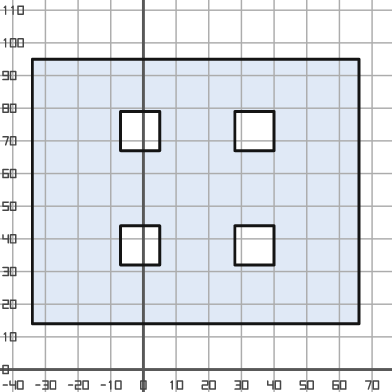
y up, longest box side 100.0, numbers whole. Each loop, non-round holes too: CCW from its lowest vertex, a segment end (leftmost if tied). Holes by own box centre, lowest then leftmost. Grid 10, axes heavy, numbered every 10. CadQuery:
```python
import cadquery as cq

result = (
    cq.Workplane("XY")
    .moveTo(-34.0, 14.0)
    .lineTo(66.0, 14.0)
    .lineTo(66.0, 95.0)
    .lineTo(-34.0, 95.0)
    .close()
    .moveTo(-7.0, 32.0)
    .lineTo(5.0, 32.0)
    .lineTo(5.0, 44.0)
    .lineTo(-7.0, 44.0)
    .close()
    .moveTo(28.0, 32.0)
    .lineTo(40.0, 32.0)
    .lineTo(40.0, 44.0)
    .lineTo(28.0, 44.0)
    .close()
    .moveTo(-7.0, 67.0)
    .lineTo(5.0, 67.0)
    .lineTo(5.0, 79.0)
    .lineTo(-7.0, 79.0)
    .close()
    .moveTo(28.0, 67.0)
    .lineTo(40.0, 67.0)
    .lineTo(40.0, 79.0)
    .lineTo(28.0, 79.0)
    .close()
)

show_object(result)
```